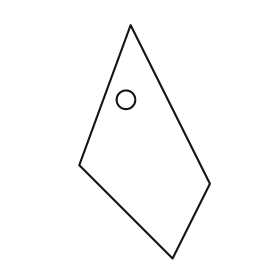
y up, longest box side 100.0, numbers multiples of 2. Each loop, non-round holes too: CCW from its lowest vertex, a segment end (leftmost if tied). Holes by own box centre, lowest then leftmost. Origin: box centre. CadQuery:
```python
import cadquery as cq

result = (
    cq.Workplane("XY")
    .moveTo(12.0, -50.0)
    .lineTo(28.0, -18.0)
    .lineTo(-6.0, 50.0)
    .lineTo(-28.0, -10.0)
    .close()
    .moveTo(-8.0, 18.0)
    .circle(4.0)
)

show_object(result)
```